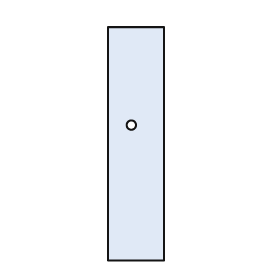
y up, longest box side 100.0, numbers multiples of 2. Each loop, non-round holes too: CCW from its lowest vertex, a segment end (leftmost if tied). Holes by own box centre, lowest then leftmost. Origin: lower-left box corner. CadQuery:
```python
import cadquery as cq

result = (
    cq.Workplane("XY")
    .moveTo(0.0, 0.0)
    .lineTo(24.0, 0.0)
    .lineTo(24.0, 100.0)
    .lineTo(0.0, 100.0)
    .close()
    .moveTo(10.0, 58.0)
    .circle(2.0)
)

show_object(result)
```